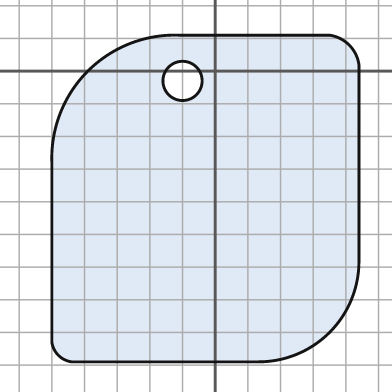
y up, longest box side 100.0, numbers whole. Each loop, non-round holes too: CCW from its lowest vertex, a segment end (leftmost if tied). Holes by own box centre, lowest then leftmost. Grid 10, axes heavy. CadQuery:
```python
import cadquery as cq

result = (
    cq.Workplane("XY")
    .moveTo(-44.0, -89.0)
    .lineTo(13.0, -89.0)
    .threePointArc((35.0, -80.0), (44.0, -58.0))
    .lineTo(44.0, 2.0)
    .threePointArc((41.0, 8.0), (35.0, 11.0))
    .lineTo(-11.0, 11.0)
    .threePointArc((-39.0, 0.0), (-50.0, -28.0))
    .lineTo(-50.0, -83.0)
    .threePointArc((-48.0, -87.0), (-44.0, -89.0))
    .close()
    .moveTo(-10.0, -3.0)
    .circle(6.0)
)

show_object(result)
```